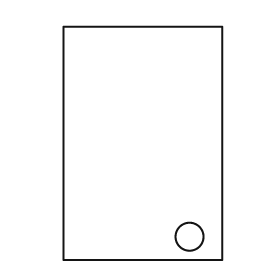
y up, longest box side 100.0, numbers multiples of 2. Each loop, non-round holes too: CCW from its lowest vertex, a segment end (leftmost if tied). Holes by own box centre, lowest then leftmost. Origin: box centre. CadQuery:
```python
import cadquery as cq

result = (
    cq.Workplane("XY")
    .moveTo(-34.0, -50.0)
    .lineTo(34.0, -50.0)
    .lineTo(34.0, 50.0)
    .lineTo(-34.0, 50.0)
    .close()
    .moveTo(20.0, -40.0)
    .circle(6.0)
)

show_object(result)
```